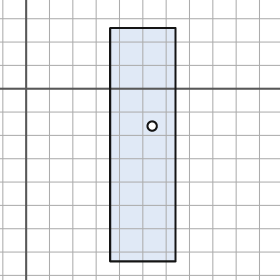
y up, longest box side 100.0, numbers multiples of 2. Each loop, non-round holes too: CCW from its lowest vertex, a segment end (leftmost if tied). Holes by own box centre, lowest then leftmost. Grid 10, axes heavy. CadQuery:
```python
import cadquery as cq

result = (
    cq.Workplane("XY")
    .moveTo(36.0, -74.0)
    .lineTo(64.0, -74.0)
    .lineTo(64.0, 26.0)
    .lineTo(36.0, 26.0)
    .close()
    .moveTo(54.0, -16.0)
    .circle(2.0)
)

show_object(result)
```